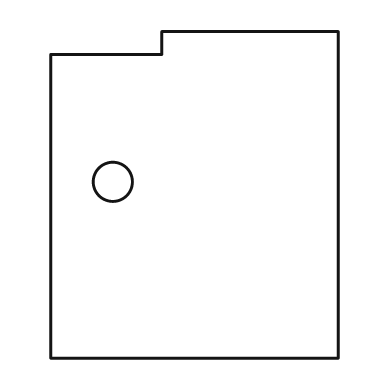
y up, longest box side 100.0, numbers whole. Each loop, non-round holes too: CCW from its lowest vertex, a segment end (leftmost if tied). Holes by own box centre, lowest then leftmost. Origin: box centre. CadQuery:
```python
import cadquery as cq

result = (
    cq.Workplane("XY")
    .moveTo(-44.0, -50.0)
    .lineTo(44.0, -50.0)
    .lineTo(44.0, 50.0)
    .lineTo(-10.0, 50.0)
    .lineTo(-10.0, 43.0)
    .lineTo(-44.0, 43.0)
    .close()
    .moveTo(-25.0, 4.0)
    .circle(6.0)
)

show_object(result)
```